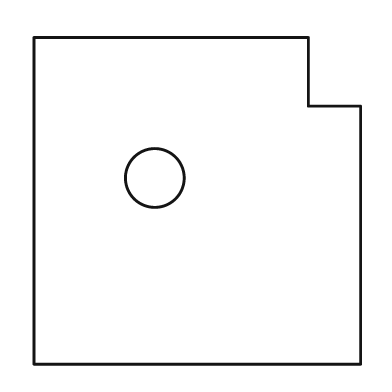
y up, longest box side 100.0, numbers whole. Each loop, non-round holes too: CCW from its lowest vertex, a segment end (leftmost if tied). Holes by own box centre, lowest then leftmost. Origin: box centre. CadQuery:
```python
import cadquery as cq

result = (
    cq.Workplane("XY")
    .moveTo(-50.0, -50.0)
    .lineTo(50.0, -50.0)
    .lineTo(50.0, 29.0)
    .lineTo(34.0, 29.0)
    .lineTo(34.0, 50.0)
    .lineTo(-50.0, 50.0)
    .close()
    .moveTo(-13.0, 7.0)
    .circle(9.0)
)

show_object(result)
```